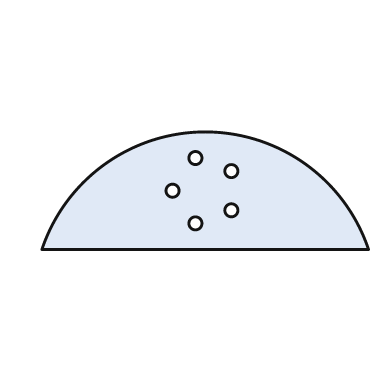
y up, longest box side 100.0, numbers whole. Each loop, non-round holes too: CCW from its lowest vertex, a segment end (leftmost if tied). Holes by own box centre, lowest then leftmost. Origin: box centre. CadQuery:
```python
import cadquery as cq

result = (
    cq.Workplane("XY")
    .moveTo(-50.0, -18.0)
    .lineTo(50.0, -18.0)
    .threePointArc((0.0, 18.0), (-50.0, -18.0))
    .close()
    .moveTo(-3.0, -10.0)
    .circle(2.0)
    .moveTo(8.0, -6.0)
    .circle(2.0)
    .moveTo(-10.0, 0.0)
    .circle(2.0)
    .moveTo(8.0, 6.0)
    .circle(2.0)
    .moveTo(-3.0, 10.0)
    .circle(2.0)
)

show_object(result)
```